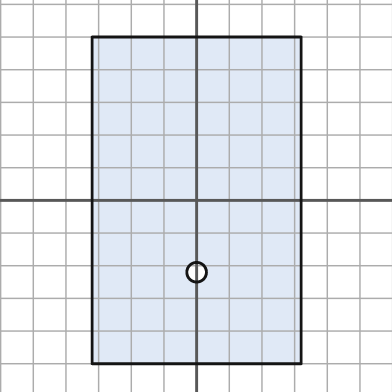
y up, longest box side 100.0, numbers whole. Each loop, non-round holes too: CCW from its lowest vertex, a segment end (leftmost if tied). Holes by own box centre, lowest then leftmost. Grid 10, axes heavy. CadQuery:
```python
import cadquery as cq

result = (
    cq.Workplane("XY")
    .moveTo(-32.0, -50.0)
    .lineTo(32.0, -50.0)
    .lineTo(32.0, 50.0)
    .lineTo(-32.0, 50.0)
    .close()
    .moveTo(0.0, -22.0)
    .circle(3.0)
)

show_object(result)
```